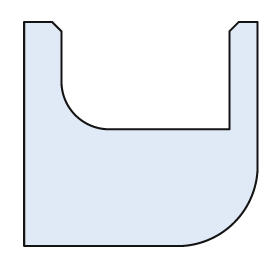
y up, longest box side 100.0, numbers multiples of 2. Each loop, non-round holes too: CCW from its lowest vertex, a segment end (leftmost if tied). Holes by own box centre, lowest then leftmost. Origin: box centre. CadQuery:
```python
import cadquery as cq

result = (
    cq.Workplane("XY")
    .moveTo(-50.0, -48.0)
    .lineTo(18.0, -48.0)
    .threePointArc((40.0, -38.0), (50.0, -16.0))
    .lineTo(50.0, 48.0)
    .lineTo(42.0, 48.0)
    .lineTo(38.0, 44.0)
    .lineTo(38.0, 2.0)
    .lineTo(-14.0, 2.0)
    .threePointArc((-28.0, 8.0), (-34.0, 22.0))
    .lineTo(-34.0, 44.0)
    .lineTo(-38.0, 48.0)
    .lineTo(-50.0, 48.0)
    .close()
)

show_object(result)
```